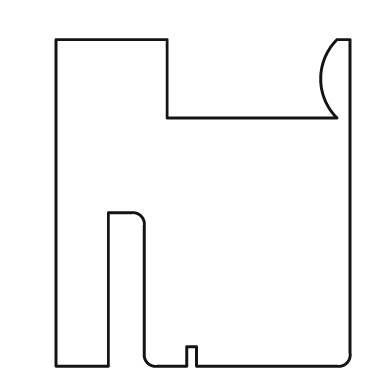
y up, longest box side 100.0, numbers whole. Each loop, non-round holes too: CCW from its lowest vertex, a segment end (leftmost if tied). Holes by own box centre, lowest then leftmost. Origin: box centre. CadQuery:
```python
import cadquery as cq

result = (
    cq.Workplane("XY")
    .moveTo(-45.0, -50.0)
    .lineTo(-29.0, -50.0)
    .lineTo(-29.0, -3.0)
    .lineTo(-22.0, -3.0)
    .threePointArc((-19.0, -4.0), (-18.0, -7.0))
    .lineTo(-18.0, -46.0)
    .threePointArc((-17.0, -49.0), (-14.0, -50.0))
    .lineTo(-5.0, -50.0)
    .lineTo(-5.0, -44.0)
    .lineTo(-2.0, -44.0)
    .lineTo(-2.0, -50.0)
    .lineTo(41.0, -50.0)
    .threePointArc((44.0, -49.0), (45.0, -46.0))
    .lineTo(45.0, 50.0)
    .lineTo(41.0, 50.0)
    .threePointArc((36.0, 38.0), (41.0, 26.0))
    .lineTo(-11.0, 26.0)
    .lineTo(-11.0, 50.0)
    .lineTo(-45.0, 50.0)
    .close()
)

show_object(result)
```